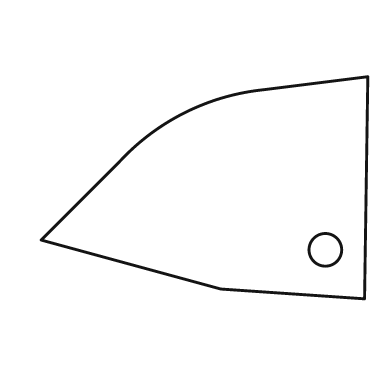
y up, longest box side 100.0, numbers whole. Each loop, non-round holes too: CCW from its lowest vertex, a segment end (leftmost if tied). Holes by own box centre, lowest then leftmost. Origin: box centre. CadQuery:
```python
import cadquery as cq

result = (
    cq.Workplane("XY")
    .moveTo(49.0, -34.0)
    .lineTo(50.0, 34.0)
    .lineTo(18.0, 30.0)
    .threePointArc((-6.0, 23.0), (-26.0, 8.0))
    .lineTo(-50.0, -16.0)
    .lineTo(5.0, -31.0)
    .close()
    .moveTo(37.0, -19.0)
    .circle(5.0)
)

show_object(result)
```